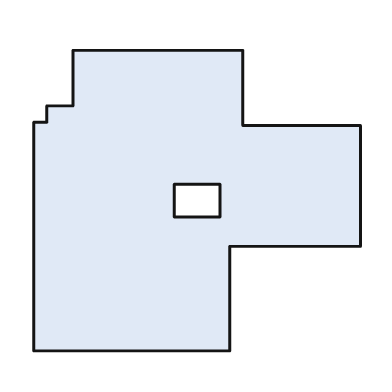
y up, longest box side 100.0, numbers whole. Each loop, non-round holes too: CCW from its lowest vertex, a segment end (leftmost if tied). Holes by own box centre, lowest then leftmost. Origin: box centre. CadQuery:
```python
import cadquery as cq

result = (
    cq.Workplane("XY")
    .moveTo(-50.0, -46.0)
    .lineTo(10.0, -46.0)
    .lineTo(10.0, -14.0)
    .lineTo(50.0, -14.0)
    .lineTo(50.0, 23.0)
    .lineTo(14.0, 23.0)
    .lineTo(14.0, 46.0)
    .lineTo(-38.0, 46.0)
    .lineTo(-38.0, 29.0)
    .lineTo(-46.0, 29.0)
    .lineTo(-46.0, 24.0)
    .lineTo(-50.0, 24.0)
    .close()
    .moveTo(-7.0, -5.0)
    .lineTo(7.0, -5.0)
    .lineTo(7.0, 5.0)
    .lineTo(-7.0, 5.0)
    .close()
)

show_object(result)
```